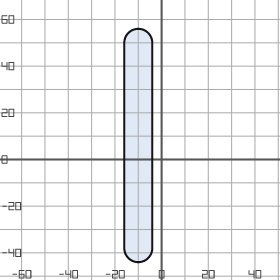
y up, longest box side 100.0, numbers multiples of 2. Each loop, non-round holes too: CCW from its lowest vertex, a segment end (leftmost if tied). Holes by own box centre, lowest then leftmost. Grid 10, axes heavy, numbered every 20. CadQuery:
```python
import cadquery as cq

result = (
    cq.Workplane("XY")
    .moveTo(-16.0, -38.0)
    .threePointArc((-10.0, -44.0), (-4.0, -38.0))
    .lineTo(-4.0, 50.0)
    .threePointArc((-10.0, 56.0), (-16.0, 50.0))
    .close()
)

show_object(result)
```